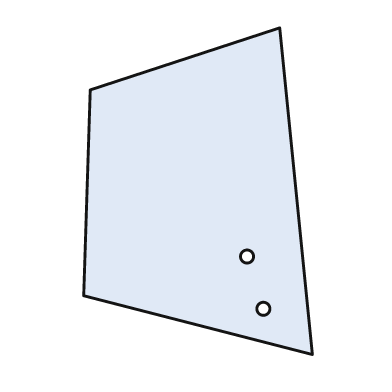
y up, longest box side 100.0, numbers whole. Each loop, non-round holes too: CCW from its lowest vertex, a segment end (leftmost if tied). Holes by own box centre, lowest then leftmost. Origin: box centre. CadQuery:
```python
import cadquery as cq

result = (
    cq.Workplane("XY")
    .moveTo(35.0, -50.0)
    .lineTo(25.0, 50.0)
    .lineTo(-33.0, 31.0)
    .lineTo(-35.0, -32.0)
    .close()
    .moveTo(20.0, -36.0)
    .circle(2.0)
    .moveTo(15.0, -20.0)
    .circle(2.0)
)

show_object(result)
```